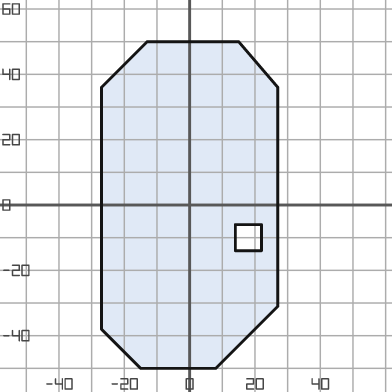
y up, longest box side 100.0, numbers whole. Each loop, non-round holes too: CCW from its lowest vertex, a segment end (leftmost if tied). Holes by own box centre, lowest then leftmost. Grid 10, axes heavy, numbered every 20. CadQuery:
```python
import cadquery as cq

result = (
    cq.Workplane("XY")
    .moveTo(-15.0, -50.0)
    .lineTo(8.0, -50.0)
    .lineTo(27.0, -31.0)
    .lineTo(27.0, 36.0)
    .lineTo(15.0, 50.0)
    .lineTo(-13.0, 50.0)
    .lineTo(-27.0, 36.0)
    .lineTo(-27.0, -38.0)
    .close()
    .moveTo(14.0, -14.0)
    .lineTo(22.0, -14.0)
    .lineTo(22.0, -6.0)
    .lineTo(14.0, -6.0)
    .close()
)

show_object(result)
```